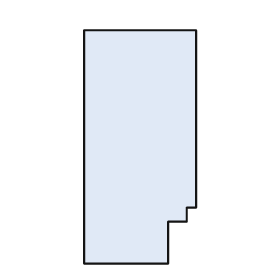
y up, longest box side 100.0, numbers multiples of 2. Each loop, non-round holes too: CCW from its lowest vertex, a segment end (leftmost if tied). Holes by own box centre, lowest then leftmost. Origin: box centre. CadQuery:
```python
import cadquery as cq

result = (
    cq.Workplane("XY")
    .moveTo(-24.0, -50.0)
    .lineTo(12.0, -50.0)
    .lineTo(12.0, -32.0)
    .lineTo(20.0, -32.0)
    .lineTo(20.0, -26.0)
    .lineTo(24.0, -26.0)
    .lineTo(24.0, 50.0)
    .lineTo(-24.0, 50.0)
    .close()
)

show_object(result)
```